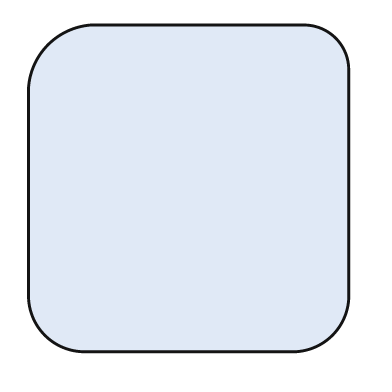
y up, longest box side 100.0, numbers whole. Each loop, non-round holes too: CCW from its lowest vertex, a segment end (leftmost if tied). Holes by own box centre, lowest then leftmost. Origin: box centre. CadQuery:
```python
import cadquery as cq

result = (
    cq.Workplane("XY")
    .moveTo(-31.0, -50.0)
    .lineTo(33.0, -50.0)
    .threePointArc((44.0, -45.0), (49.0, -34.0))
    .lineTo(49.0, 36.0)
    .threePointArc((45.0, 46.0), (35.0, 50.0))
    .lineTo(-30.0, 50.0)
    .threePointArc((-43.0, 44.0), (-49.0, 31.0))
    .lineTo(-49.0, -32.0)
    .threePointArc((-44.0, -45.0), (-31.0, -50.0))
    .close()
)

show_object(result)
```